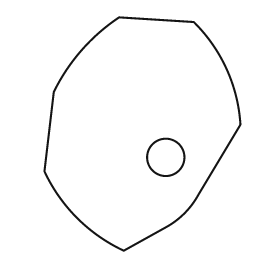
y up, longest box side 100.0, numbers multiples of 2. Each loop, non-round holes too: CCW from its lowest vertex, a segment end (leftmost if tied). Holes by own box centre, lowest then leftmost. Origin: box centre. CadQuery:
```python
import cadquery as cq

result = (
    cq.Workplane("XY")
    .moveTo(-8.0, -50.0)
    .lineTo(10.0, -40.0)
    .threePointArc((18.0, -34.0), (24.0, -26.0))
    .lineTo(42.0, 4.0)
    .threePointArc((36.0, 28.0), (22.0, 48.0))
    .lineTo(-10.0, 50.0)
    .threePointArc((-26.0, 36.0), (-38.0, 18.0))
    .lineTo(-42.0, -16.0)
    .threePointArc((-28.0, -36.0), (-8.0, -50.0))
    .close()
    .moveTo(10.0, -10.0)
    .circle(8.0)
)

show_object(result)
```